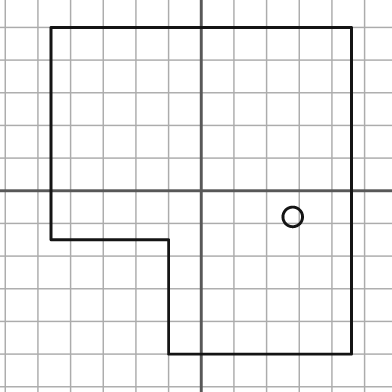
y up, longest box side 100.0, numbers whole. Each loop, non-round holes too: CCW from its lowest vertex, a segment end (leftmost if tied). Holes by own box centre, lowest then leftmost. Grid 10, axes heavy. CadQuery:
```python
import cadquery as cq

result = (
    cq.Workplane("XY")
    .moveTo(-10.0, -50.0)
    .lineTo(46.0, -50.0)
    .lineTo(46.0, 50.0)
    .lineTo(-46.0, 50.0)
    .lineTo(-46.0, -15.0)
    .lineTo(-10.0, -15.0)
    .close()
    .moveTo(28.0, -8.0)
    .circle(3.0)
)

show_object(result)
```